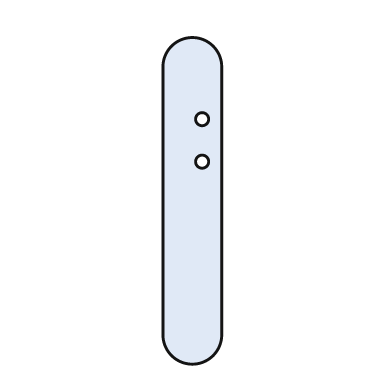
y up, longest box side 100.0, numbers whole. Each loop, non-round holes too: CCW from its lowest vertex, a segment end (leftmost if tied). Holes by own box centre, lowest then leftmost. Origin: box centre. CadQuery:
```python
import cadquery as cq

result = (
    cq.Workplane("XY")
    .moveTo(-9.0, -41.0)
    .threePointArc((0.0, -50.0), (9.0, -41.0))
    .lineTo(9.0, 41.0)
    .threePointArc((0.0, 50.0), (-9.0, 41.0))
    .close()
    .moveTo(3.0, 12.0)
    .circle(2.0)
    .moveTo(3.0, 25.0)
    .circle(2.0)
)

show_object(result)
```